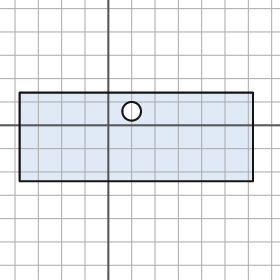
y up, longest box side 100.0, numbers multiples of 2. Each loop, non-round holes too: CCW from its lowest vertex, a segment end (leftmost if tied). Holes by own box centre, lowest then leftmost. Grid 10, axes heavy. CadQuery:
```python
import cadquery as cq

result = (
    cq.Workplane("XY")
    .moveTo(-38.0, -24.0)
    .lineTo(62.0, -24.0)
    .lineTo(62.0, 14.0)
    .lineTo(-38.0, 14.0)
    .close()
    .moveTo(10.0, 6.0)
    .circle(4.0)
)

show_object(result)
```